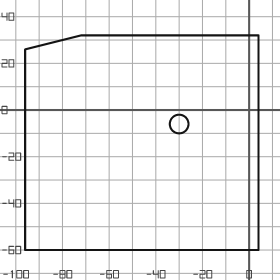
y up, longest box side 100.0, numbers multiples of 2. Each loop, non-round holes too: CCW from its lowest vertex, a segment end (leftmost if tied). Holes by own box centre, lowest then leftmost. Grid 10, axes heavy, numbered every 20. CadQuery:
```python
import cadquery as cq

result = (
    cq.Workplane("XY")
    .moveTo(-96.0, -60.0)
    .lineTo(4.0, -60.0)
    .lineTo(4.0, 32.0)
    .lineTo(-72.0, 32.0)
    .lineTo(-96.0, 26.0)
    .close()
    .moveTo(-30.0, -6.0)
    .circle(4.0)
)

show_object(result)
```